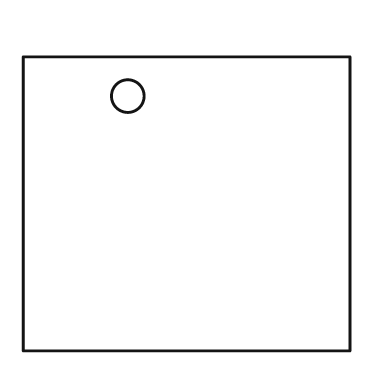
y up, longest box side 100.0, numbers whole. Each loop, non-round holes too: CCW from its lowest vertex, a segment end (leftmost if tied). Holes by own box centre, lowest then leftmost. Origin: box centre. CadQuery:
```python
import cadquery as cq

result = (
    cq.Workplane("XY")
    .moveTo(-50.0, -45.0)
    .lineTo(50.0, -45.0)
    .lineTo(50.0, 45.0)
    .lineTo(-50.0, 45.0)
    .close()
    .moveTo(-18.0, 33.0)
    .circle(5.0)
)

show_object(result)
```